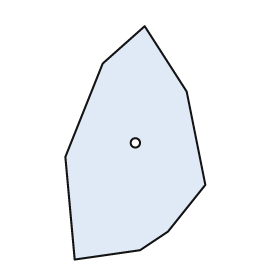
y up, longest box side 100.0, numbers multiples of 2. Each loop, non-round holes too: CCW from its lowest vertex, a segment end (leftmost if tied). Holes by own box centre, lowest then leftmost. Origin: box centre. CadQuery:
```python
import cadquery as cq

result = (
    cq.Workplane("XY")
    .moveTo(-26.0, -50.0)
    .lineTo(2.0, -46.0)
    .lineTo(14.0, -38.0)
    .lineTo(30.0, -18.0)
    .lineTo(22.0, 22.0)
    .lineTo(4.0, 50.0)
    .lineTo(-14.0, 34.0)
    .lineTo(-30.0, -6.0)
    .close()
    .moveTo(0.0, 0.0)
    .circle(2.0)
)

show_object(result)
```